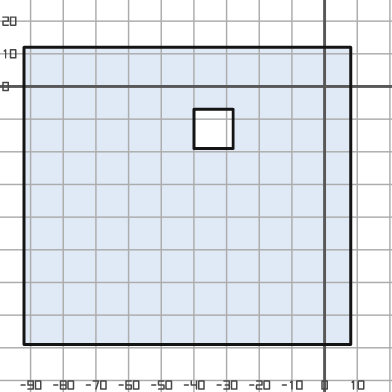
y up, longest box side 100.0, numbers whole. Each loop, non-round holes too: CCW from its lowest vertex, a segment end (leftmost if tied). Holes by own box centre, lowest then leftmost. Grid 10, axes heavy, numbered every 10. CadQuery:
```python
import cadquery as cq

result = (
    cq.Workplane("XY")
    .moveTo(-92.0, -79.0)
    .lineTo(8.0, -79.0)
    .lineTo(8.0, 12.0)
    .lineTo(-92.0, 12.0)
    .close()
    .moveTo(-40.0, -19.0)
    .lineTo(-28.0, -19.0)
    .lineTo(-28.0, -7.0)
    .lineTo(-40.0, -7.0)
    .close()
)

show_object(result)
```